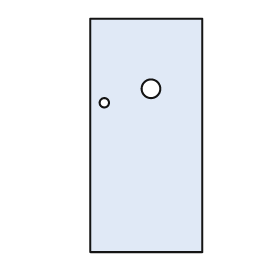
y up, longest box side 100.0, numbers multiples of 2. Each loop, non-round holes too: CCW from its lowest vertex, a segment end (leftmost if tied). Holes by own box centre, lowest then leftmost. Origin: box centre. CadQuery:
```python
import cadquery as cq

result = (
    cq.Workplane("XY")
    .moveTo(-24.0, -50.0)
    .lineTo(24.0, -50.0)
    .lineTo(24.0, 50.0)
    .lineTo(-24.0, 50.0)
    .close()
    .moveTo(-18.0, 14.0)
    .circle(2.0)
    .moveTo(2.0, 20.0)
    .circle(4.0)
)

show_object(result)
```